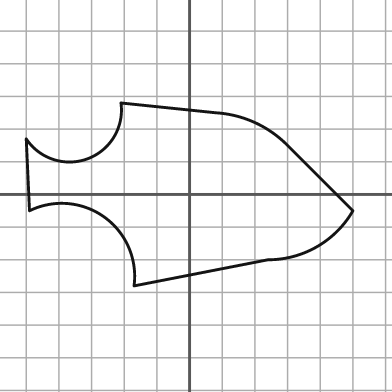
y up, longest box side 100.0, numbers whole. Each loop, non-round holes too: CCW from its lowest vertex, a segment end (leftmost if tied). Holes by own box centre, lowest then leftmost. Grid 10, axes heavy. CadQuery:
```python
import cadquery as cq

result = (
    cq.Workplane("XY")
    .moveTo(-17.0, -28.0)
    .lineTo(24.0, -20.0)
    .threePointArc((39.0, -16.0), (50.0, -5.0))
    .lineTo(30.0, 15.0)
    .threePointArc((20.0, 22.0), (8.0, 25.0))
    .lineTo(-21.0, 28.0)
    .threePointArc((-31.0, 11.0), (-50.0, 17.0))
    .lineTo(-49.0, -5.0)
    .threePointArc((-26.0, -7.0), (-17.0, -28.0))
    .close()
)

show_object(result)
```